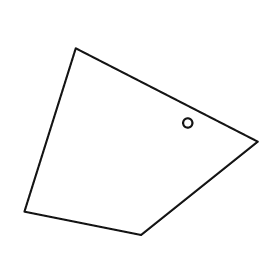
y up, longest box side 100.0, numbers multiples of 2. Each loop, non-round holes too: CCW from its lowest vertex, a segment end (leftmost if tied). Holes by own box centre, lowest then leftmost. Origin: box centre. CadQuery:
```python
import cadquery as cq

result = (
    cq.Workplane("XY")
    .moveTo(0.0, -40.0)
    .lineTo(50.0, 0.0)
    .lineTo(-28.0, 40.0)
    .lineTo(-50.0, -30.0)
    .close()
    .moveTo(20.0, 8.0)
    .circle(2.0)
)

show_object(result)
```